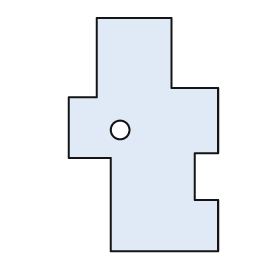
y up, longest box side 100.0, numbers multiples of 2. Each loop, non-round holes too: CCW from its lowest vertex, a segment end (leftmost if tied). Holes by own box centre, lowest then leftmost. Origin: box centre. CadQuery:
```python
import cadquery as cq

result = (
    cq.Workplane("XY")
    .moveTo(-14.0, -50.0)
    .lineTo(32.0, -50.0)
    .lineTo(32.0, -28.0)
    .lineTo(22.0, -28.0)
    .lineTo(22.0, -8.0)
    .lineTo(32.0, -8.0)
    .lineTo(32.0, 20.0)
    .lineTo(12.0, 20.0)
    .lineTo(12.0, 50.0)
    .lineTo(-20.0, 50.0)
    .lineTo(-20.0, 16.0)
    .lineTo(-32.0, 16.0)
    .lineTo(-32.0, -10.0)
    .lineTo(-14.0, -10.0)
    .close()
    .moveTo(-10.0, 2.0)
    .circle(4.0)
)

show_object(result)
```